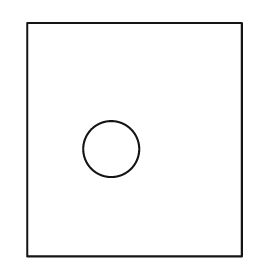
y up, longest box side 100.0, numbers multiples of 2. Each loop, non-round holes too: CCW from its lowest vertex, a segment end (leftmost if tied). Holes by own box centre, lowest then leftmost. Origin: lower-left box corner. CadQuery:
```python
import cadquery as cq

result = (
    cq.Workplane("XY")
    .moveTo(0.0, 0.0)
    .lineTo(92.0, 0.0)
    .lineTo(92.0, 100.0)
    .lineTo(0.0, 100.0)
    .close()
    .moveTo(36.0, 46.0)
    .circle(12.0)
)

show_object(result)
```